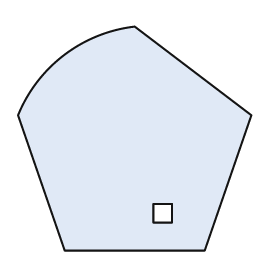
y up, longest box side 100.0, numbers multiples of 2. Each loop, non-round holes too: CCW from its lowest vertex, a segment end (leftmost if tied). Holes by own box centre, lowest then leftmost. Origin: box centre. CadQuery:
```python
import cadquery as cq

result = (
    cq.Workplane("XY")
    .moveTo(-30.0, -48.0)
    .lineTo(30.0, -48.0)
    .lineTo(50.0, 10.0)
    .lineTo(0.0, 48.0)
    .threePointArc((-30.0, 36.0), (-50.0, 10.0))
    .close()
    .moveTo(8.0, -36.0)
    .lineTo(16.0, -36.0)
    .lineTo(16.0, -28.0)
    .lineTo(8.0, -28.0)
    .close()
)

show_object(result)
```